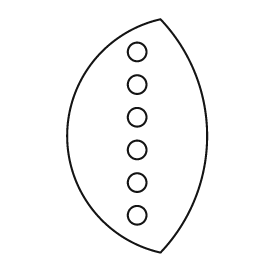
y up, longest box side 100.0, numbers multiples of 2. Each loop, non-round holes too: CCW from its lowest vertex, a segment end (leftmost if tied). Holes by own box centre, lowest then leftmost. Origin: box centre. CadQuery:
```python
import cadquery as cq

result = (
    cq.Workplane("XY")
    .moveTo(10.0, -50.0)
    .threePointArc((30.0, 0.0), (10.0, 50.0))
    .threePointArc((-30.0, 0.0), (10.0, -50.0))
    .close()
    .moveTo(0.0, -34.0)
    .circle(4.0)
    .moveTo(0.0, -20.0)
    .circle(4.0)
    .moveTo(0.0, -6.0)
    .circle(4.0)
    .moveTo(0.0, 8.0)
    .circle(4.0)
    .moveTo(0.0, 22.0)
    .circle(4.0)
    .moveTo(0.0, 36.0)
    .circle(4.0)
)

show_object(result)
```